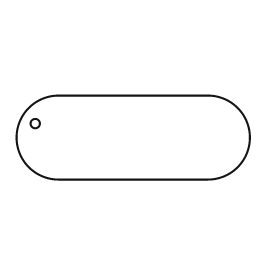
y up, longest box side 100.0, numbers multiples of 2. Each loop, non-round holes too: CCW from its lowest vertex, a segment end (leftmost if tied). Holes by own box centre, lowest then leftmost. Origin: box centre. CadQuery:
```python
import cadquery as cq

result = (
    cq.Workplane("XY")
    .moveTo(-32.0, -18.0)
    .lineTo(32.0, -18.0)
    .threePointArc((50.0, 0.0), (32.0, 18.0))
    .lineTo(-32.0, 18.0)
    .threePointArc((-50.0, 0.0), (-32.0, -18.0))
    .close()
    .moveTo(-42.0, 6.0)
    .circle(2.0)
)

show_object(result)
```